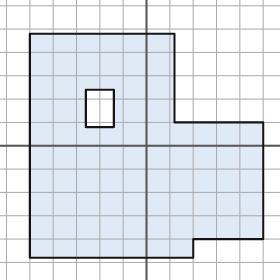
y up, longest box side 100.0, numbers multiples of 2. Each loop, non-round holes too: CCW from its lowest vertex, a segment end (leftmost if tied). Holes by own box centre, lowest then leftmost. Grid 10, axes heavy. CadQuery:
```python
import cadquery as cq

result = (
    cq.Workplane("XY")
    .moveTo(-50.0, -48.0)
    .lineTo(20.0, -48.0)
    .lineTo(20.0, -40.0)
    .lineTo(50.0, -40.0)
    .lineTo(50.0, 10.0)
    .lineTo(12.0, 10.0)
    .lineTo(12.0, 48.0)
    .lineTo(-50.0, 48.0)
    .close()
    .moveTo(-26.0, 8.0)
    .lineTo(-14.0, 8.0)
    .lineTo(-14.0, 24.0)
    .lineTo(-26.0, 24.0)
    .close()
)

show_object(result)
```